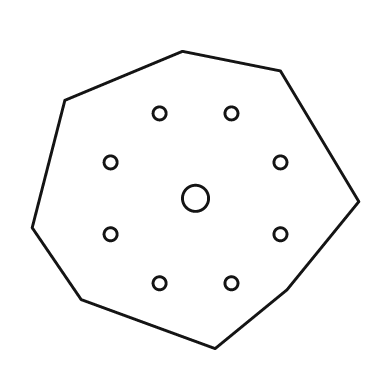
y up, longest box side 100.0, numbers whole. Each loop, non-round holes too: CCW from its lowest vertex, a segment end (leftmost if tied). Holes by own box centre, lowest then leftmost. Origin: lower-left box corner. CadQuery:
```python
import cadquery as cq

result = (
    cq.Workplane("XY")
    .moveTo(56.0, 0.0)
    .lineTo(78.0, 18.0)
    .lineTo(100.0, 45.0)
    .lineTo(76.0, 85.0)
    .lineTo(46.0, 91.0)
    .lineTo(10.0, 76.0)
    .lineTo(0.0, 37.0)
    .lineTo(15.0, 15.0)
    .close()
    .moveTo(39.0, 20.0)
    .circle(2.0)
    .moveTo(61.0, 20.0)
    .circle(2.0)
    .moveTo(24.0, 35.0)
    .circle(2.0)
    .moveTo(76.0, 35.0)
    .circle(2.0)
    .moveTo(50.0, 46.0)
    .circle(4.0)
    .moveTo(24.0, 57.0)
    .circle(2.0)
    .moveTo(76.0, 57.0)
    .circle(2.0)
    .moveTo(39.0, 72.0)
    .circle(2.0)
    .moveTo(61.0, 72.0)
    .circle(2.0)
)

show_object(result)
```